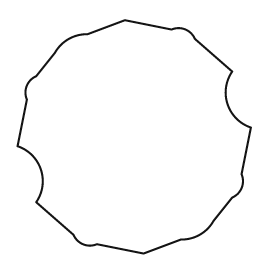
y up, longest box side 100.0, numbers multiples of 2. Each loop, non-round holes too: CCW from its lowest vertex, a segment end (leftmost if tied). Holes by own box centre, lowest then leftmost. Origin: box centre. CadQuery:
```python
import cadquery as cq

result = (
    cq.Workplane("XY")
    .moveTo(4.0, -50.0)
    .lineTo(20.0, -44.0)
    .threePointArc((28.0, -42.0), (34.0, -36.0))
    .lineTo(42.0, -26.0)
    .threePointArc((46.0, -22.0), (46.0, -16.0))
    .lineTo(50.0, 4.0)
    .threePointArc((40.0, 14.0), (42.0, 28.0))
    .lineTo(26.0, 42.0)
    .threePointArc((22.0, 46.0), (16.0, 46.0))
    .lineTo(-4.0, 50.0)
    .lineTo(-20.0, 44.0)
    .threePointArc((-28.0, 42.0), (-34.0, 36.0))
    .lineTo(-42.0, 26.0)
    .threePointArc((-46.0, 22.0), (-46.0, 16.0))
    .lineTo(-50.0, -4.0)
    .threePointArc((-40.0, -14.0), (-42.0, -28.0))
    .lineTo(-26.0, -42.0)
    .threePointArc((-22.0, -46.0), (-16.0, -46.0))
    .close()
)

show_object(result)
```